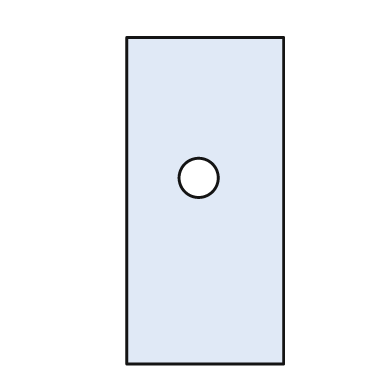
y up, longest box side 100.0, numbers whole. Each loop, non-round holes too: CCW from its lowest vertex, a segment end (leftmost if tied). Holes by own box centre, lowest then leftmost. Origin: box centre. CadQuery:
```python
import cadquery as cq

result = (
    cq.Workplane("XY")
    .moveTo(-24.0, -50.0)
    .lineTo(24.0, -50.0)
    .lineTo(24.0, 50.0)
    .lineTo(-24.0, 50.0)
    .close()
    .moveTo(-2.0, 7.0)
    .circle(6.0)
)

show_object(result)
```